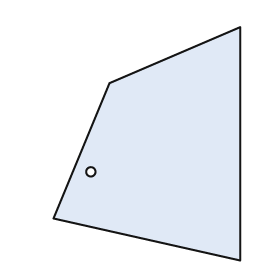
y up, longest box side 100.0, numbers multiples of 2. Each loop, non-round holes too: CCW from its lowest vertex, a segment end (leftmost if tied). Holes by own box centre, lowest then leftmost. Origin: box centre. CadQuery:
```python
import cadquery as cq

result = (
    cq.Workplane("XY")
    .moveTo(40.0, -50.0)
    .lineTo(40.0, 50.0)
    .lineTo(-16.0, 26.0)
    .lineTo(-40.0, -32.0)
    .close()
    .moveTo(-24.0, -12.0)
    .circle(2.0)
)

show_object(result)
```